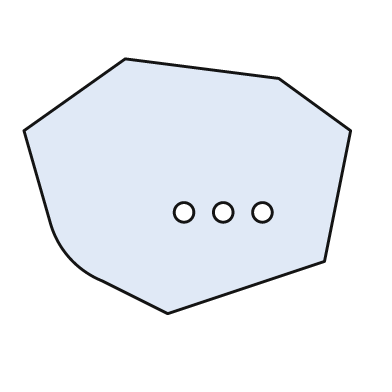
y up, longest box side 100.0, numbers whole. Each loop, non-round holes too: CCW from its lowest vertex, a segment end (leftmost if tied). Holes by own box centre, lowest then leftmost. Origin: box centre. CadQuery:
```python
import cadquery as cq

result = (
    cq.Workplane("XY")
    .moveTo(-6.0, -39.0)
    .lineTo(42.0, -23.0)
    .lineTo(50.0, 17.0)
    .lineTo(28.0, 33.0)
    .lineTo(-19.0, 39.0)
    .lineTo(-50.0, 17.0)
    .lineTo(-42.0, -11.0)
    .threePointArc((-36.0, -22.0), (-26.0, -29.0))
    .close()
    .moveTo(-1.0, -8.0)
    .circle(3.0)
    .moveTo(11.0, -8.0)
    .circle(3.0)
    .moveTo(23.0, -8.0)
    .circle(3.0)
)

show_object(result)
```